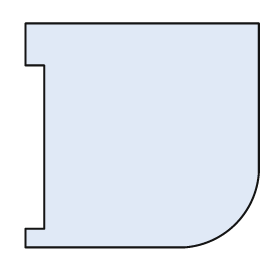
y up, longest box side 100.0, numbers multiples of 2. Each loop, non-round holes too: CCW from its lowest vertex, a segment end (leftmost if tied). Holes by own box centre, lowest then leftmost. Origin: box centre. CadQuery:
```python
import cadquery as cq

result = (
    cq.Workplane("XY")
    .moveTo(-50.0, -48.0)
    .lineTo(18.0, -48.0)
    .threePointArc((40.0, -38.0), (50.0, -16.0))
    .lineTo(50.0, 48.0)
    .lineTo(-50.0, 48.0)
    .lineTo(-50.0, 30.0)
    .lineTo(-42.0, 30.0)
    .lineTo(-42.0, -40.0)
    .lineTo(-50.0, -40.0)
    .close()
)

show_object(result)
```